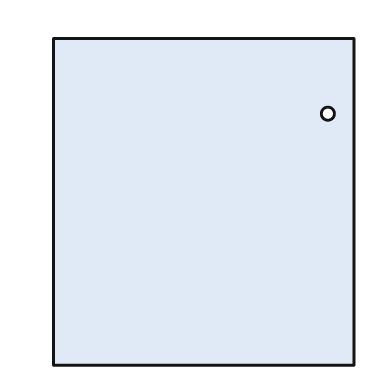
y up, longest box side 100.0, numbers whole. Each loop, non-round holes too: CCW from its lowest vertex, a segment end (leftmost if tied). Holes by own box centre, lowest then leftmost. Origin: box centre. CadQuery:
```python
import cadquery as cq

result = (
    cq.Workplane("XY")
    .moveTo(-46.0, -50.0)
    .lineTo(46.0, -50.0)
    .lineTo(46.0, 50.0)
    .lineTo(-46.0, 50.0)
    .close()
    .moveTo(38.0, 27.0)
    .circle(2.0)
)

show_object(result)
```